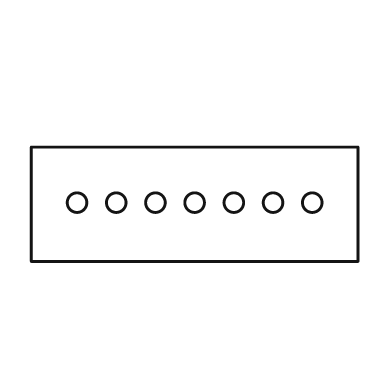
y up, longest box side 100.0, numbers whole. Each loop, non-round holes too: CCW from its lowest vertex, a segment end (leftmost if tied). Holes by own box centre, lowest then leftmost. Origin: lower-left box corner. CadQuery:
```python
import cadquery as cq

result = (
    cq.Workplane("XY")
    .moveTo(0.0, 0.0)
    .lineTo(100.0, 0.0)
    .lineTo(100.0, 35.0)
    .lineTo(0.0, 35.0)
    .close()
    .moveTo(14.0, 18.0)
    .circle(3.0)
    .moveTo(26.0, 18.0)
    .circle(3.0)
    .moveTo(38.0, 18.0)
    .circle(3.0)
    .moveTo(50.0, 18.0)
    .circle(3.0)
    .moveTo(62.0, 18.0)
    .circle(3.0)
    .moveTo(74.0, 18.0)
    .circle(3.0)
    .moveTo(86.0, 18.0)
    .circle(3.0)
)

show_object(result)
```